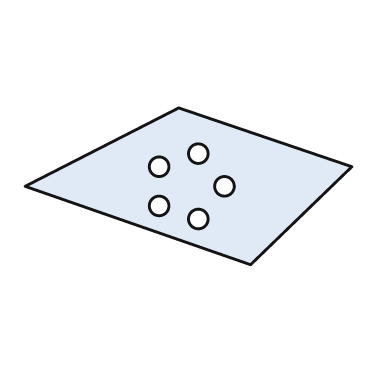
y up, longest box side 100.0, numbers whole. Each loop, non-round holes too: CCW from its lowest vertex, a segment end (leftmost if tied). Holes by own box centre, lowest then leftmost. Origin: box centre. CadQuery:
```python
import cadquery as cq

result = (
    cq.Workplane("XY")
    .moveTo(19.0, -24.0)
    .lineTo(50.0, 6.0)
    .lineTo(-3.0, 24.0)
    .lineTo(-50.0, 0.0)
    .close()
    .moveTo(3.0, -10.0)
    .circle(3.0)
    .moveTo(-9.0, -6.0)
    .circle(3.0)
    .moveTo(11.0, 0.0)
    .circle(3.0)
    .moveTo(-9.0, 6.0)
    .circle(3.0)
    .moveTo(3.0, 10.0)
    .circle(3.0)
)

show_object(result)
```